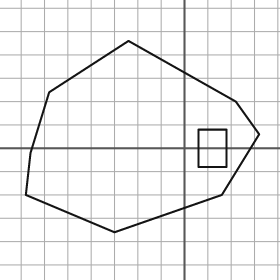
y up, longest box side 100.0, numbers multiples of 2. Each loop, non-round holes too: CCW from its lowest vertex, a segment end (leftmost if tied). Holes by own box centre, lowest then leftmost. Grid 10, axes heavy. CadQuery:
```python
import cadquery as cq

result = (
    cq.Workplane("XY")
    .moveTo(-30.0, -36.0)
    .lineTo(16.0, -20.0)
    .lineTo(32.0, 6.0)
    .lineTo(22.0, 20.0)
    .lineTo(-24.0, 46.0)
    .lineTo(-58.0, 24.0)
    .lineTo(-66.0, -2.0)
    .lineTo(-68.0, -20.0)
    .close()
    .moveTo(6.0, -8.0)
    .lineTo(18.0, -8.0)
    .lineTo(18.0, 8.0)
    .lineTo(6.0, 8.0)
    .close()
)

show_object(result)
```